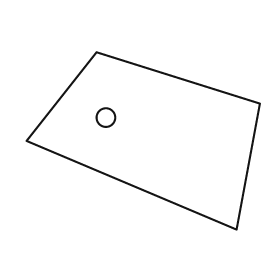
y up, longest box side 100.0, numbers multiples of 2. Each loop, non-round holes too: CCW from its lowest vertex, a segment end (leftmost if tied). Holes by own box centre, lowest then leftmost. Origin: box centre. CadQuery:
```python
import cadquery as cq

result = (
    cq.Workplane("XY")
    .moveTo(40.0, -38.0)
    .lineTo(50.0, 16.0)
    .lineTo(-20.0, 38.0)
    .lineTo(-50.0, 0.0)
    .close()
    .moveTo(-16.0, 10.0)
    .circle(4.0)
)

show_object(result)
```